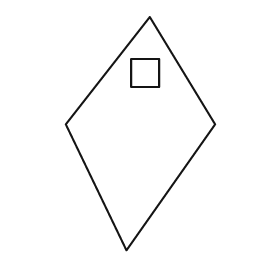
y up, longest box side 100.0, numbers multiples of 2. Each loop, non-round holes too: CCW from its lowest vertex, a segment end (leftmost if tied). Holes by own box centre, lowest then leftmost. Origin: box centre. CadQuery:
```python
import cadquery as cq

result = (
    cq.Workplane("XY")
    .moveTo(-6.0, -50.0)
    .lineTo(32.0, 4.0)
    .lineTo(4.0, 50.0)
    .lineTo(-32.0, 4.0)
    .close()
    .moveTo(-4.0, 20.0)
    .lineTo(8.0, 20.0)
    .lineTo(8.0, 32.0)
    .lineTo(-4.0, 32.0)
    .close()
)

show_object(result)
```